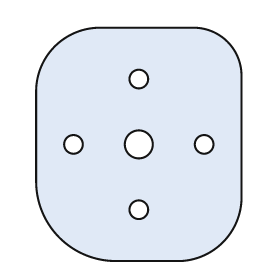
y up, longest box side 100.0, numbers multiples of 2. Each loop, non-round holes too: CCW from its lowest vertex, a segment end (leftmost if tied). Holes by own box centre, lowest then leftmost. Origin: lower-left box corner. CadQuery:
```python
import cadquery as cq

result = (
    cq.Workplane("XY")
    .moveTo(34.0, 0.0)
    .lineTo(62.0, 0.0)
    .threePointArc((80.0, 8.0), (88.0, 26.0))
    .lineTo(88.0, 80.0)
    .threePointArc((82.0, 94.0), (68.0, 100.0))
    .lineTo(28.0, 100.0)
    .threePointArc((8.0, 92.0), (0.0, 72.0))
    .lineTo(0.0, 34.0)
    .threePointArc((10.0, 10.0), (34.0, 0.0))
    .close()
    .moveTo(44.0, 22.0)
    .circle(4.0)
    .moveTo(16.0, 50.0)
    .circle(4.0)
    .moveTo(44.0, 50.0)
    .circle(6.0)
    .moveTo(72.0, 50.0)
    .circle(4.0)
    .moveTo(44.0, 78.0)
    .circle(4.0)
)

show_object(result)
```